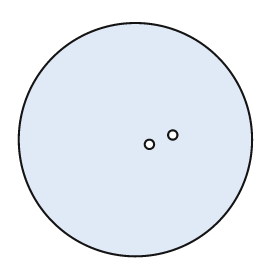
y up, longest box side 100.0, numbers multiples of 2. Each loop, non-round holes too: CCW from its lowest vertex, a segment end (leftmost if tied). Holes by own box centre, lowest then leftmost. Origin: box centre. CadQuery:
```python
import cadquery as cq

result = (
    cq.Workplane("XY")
    .moveTo(0.0, 0.0)
    .circle(50.0)
    .moveTo(6.0, -2.0)
    .circle(2.0)
    .moveTo(16.0, 2.0)
    .circle(2.0)
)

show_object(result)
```